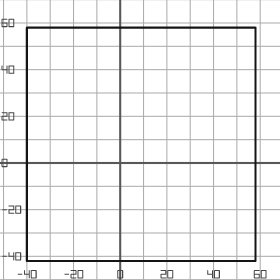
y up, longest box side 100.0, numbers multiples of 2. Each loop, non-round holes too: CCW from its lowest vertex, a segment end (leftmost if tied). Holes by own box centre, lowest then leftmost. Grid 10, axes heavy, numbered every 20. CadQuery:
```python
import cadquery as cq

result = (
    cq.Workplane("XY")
    .moveTo(-40.0, -42.0)
    .lineTo(58.0, -42.0)
    .lineTo(58.0, 58.0)
    .lineTo(-40.0, 58.0)
    .close()
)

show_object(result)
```